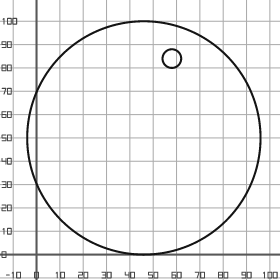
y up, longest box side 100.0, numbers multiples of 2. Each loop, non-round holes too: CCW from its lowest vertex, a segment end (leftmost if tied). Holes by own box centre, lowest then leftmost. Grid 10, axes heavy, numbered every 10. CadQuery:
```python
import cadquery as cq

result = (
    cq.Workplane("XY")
    .moveTo(46.0, 50.0)
    .circle(50.0)
    .moveTo(58.0, 84.0)
    .circle(4.0)
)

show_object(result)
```